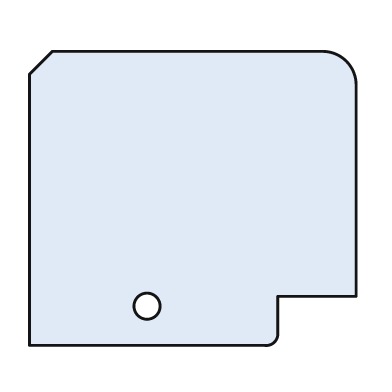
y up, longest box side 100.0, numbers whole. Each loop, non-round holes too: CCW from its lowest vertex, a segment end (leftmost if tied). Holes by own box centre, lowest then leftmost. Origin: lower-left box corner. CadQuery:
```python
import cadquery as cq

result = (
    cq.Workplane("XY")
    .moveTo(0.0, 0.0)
    .lineTo(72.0, 0.0)
    .threePointArc((75.0, 1.0), (76.0, 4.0))
    .lineTo(76.0, 15.0)
    .lineTo(100.0, 15.0)
    .lineTo(100.0, 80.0)
    .threePointArc((97.0, 87.0), (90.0, 90.0))
    .lineTo(7.0, 90.0)
    .lineTo(0.0, 83.0)
    .close()
    .moveTo(36.0, 12.0)
    .circle(4.0)
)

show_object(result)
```